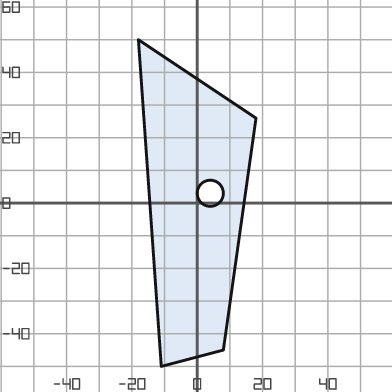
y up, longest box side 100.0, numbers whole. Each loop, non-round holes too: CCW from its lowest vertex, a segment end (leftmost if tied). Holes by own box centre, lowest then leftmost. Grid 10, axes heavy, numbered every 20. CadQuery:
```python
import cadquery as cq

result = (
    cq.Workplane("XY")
    .moveTo(-11.0, -50.0)
    .lineTo(8.0, -45.0)
    .lineTo(18.0, 26.0)
    .lineTo(-18.0, 50.0)
    .close()
    .moveTo(4.0, 3.0)
    .circle(4.0)
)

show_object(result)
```